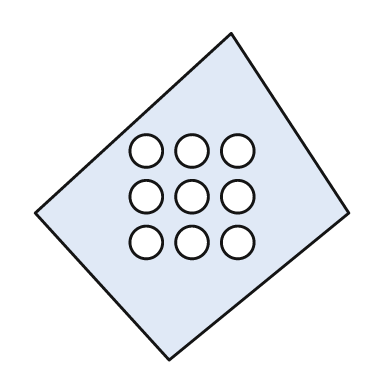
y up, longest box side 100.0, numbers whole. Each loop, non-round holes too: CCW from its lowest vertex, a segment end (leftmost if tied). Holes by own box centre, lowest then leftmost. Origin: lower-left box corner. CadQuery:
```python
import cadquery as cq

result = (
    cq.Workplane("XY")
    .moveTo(41.0, 0.0)
    .lineTo(96.0, 45.0)
    .lineTo(60.0, 100.0)
    .lineTo(0.0, 45.0)
    .close()
    .moveTo(34.0, 36.0)
    .circle(5.0)
    .moveTo(48.0, 36.0)
    .circle(5.0)
    .moveTo(62.0, 36.0)
    .circle(5.0)
    .moveTo(34.0, 50.0)
    .circle(5.0)
    .moveTo(48.0, 50.0)
    .circle(5.0)
    .moveTo(62.0, 50.0)
    .circle(5.0)
    .moveTo(34.0, 64.0)
    .circle(5.0)
    .moveTo(48.0, 64.0)
    .circle(5.0)
    .moveTo(62.0, 64.0)
    .circle(5.0)
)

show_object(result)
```